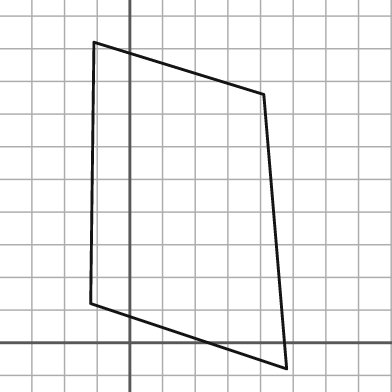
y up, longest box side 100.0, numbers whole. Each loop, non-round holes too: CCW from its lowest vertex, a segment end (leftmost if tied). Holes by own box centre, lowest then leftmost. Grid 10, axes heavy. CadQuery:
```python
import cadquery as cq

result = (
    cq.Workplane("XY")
    .moveTo(48.0, -8.0)
    .lineTo(41.0, 76.0)
    .lineTo(-11.0, 92.0)
    .lineTo(-12.0, 12.0)
    .close()
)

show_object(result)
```